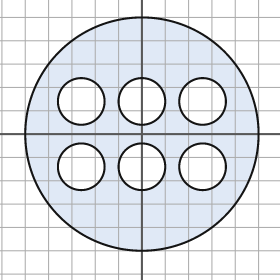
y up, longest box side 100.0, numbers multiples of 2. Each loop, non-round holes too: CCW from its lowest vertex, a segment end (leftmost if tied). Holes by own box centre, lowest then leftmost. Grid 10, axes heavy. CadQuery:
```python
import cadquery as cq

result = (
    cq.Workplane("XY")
    .moveTo(0.0, 0.0)
    .circle(50.0)
    .moveTo(-26.0, -14.0)
    .circle(10.0)
    .moveTo(0.0, -14.0)
    .circle(10.0)
    .moveTo(26.0, -14.0)
    .circle(10.0)
    .moveTo(-26.0, 14.0)
    .circle(10.0)
    .moveTo(0.0, 14.0)
    .circle(10.0)
    .moveTo(26.0, 14.0)
    .circle(10.0)
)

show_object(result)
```